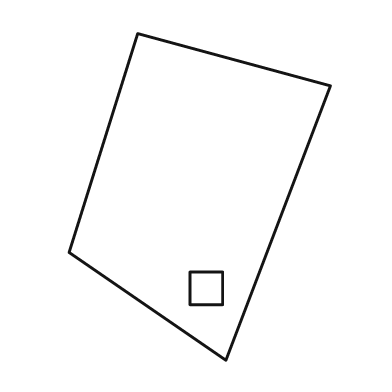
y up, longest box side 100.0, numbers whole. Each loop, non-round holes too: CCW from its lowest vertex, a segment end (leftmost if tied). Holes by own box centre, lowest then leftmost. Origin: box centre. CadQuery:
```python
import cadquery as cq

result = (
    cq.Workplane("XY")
    .moveTo(8.0, -50.0)
    .lineTo(40.0, 34.0)
    .lineTo(-19.0, 50.0)
    .lineTo(-40.0, -17.0)
    .close()
    .moveTo(-3.0, -33.0)
    .lineTo(7.0, -33.0)
    .lineTo(7.0, -23.0)
    .lineTo(-3.0, -23.0)
    .close()
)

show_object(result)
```